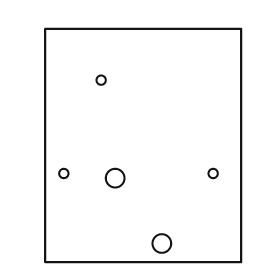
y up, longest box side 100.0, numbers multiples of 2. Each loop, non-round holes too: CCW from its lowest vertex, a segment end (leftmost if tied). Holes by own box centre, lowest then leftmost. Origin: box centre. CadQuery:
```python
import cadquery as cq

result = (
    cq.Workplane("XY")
    .moveTo(-42.0, -50.0)
    .lineTo(42.0, -50.0)
    .lineTo(42.0, 50.0)
    .lineTo(-42.0, 50.0)
    .close()
    .moveTo(8.0, -42.0)
    .circle(4.0)
    .moveTo(-12.0, -14.0)
    .circle(4.0)
    .moveTo(-34.0, -12.0)
    .circle(2.0)
    .moveTo(30.0, -12.0)
    .circle(2.0)
    .moveTo(-18.0, 28.0)
    .circle(2.0)
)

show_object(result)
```